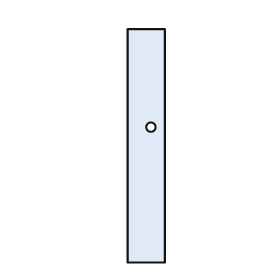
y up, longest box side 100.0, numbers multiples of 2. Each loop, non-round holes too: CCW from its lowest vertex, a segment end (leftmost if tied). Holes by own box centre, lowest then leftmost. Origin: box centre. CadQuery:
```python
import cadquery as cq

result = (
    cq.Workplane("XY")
    .moveTo(-8.0, -50.0)
    .lineTo(8.0, -50.0)
    .lineTo(8.0, 50.0)
    .lineTo(-8.0, 50.0)
    .close()
    .moveTo(2.0, 8.0)
    .circle(2.0)
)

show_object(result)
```